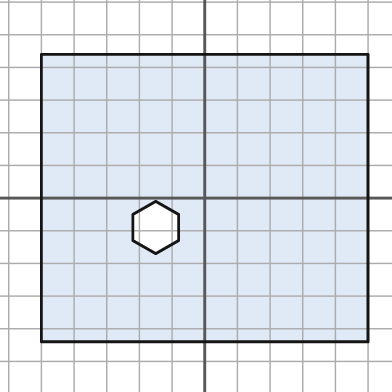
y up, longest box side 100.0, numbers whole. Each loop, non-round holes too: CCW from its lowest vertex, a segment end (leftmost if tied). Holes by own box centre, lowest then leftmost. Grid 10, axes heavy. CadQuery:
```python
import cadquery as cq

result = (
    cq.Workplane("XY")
    .moveTo(-50.0, -44.0)
    .lineTo(50.0, -44.0)
    .lineTo(50.0, 44.0)
    .lineTo(-50.0, 44.0)
    .close()
    .moveTo(-15.0, -17.0)
    .lineTo(-8.0, -13.0)
    .lineTo(-8.0, -5.0)
    .lineTo(-15.0, -1.0)
    .lineTo(-22.0, -5.0)
    .lineTo(-22.0, -13.0)
    .close()
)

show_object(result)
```